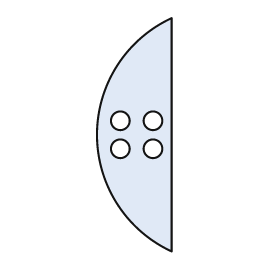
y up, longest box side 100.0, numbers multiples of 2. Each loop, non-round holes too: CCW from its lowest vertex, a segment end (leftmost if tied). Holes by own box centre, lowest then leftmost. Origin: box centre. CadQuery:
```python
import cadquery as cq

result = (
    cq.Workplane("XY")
    .moveTo(16.0, -50.0)
    .lineTo(16.0, 50.0)
    .threePointArc((-16.0, 0.0), (16.0, -50.0))
    .close()
    .moveTo(-6.0, -6.0)
    .circle(4.0)
    .moveTo(8.0, -6.0)
    .circle(4.0)
    .moveTo(-6.0, 6.0)
    .circle(4.0)
    .moveTo(8.0, 6.0)
    .circle(4.0)
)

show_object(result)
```